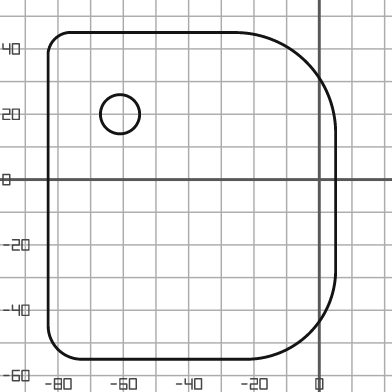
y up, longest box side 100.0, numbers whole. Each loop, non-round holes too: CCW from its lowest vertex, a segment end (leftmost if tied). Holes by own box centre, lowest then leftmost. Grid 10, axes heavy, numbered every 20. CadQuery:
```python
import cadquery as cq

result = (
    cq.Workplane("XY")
    .moveTo(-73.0, -55.0)
    .lineTo(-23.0, -55.0)
    .threePointArc((-3.0, -47.0), (5.0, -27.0))
    .lineTo(5.0, 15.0)
    .threePointArc((-4.0, 36.0), (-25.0, 45.0))
    .lineTo(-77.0, 45.0)
    .threePointArc((-81.0, 43.0), (-83.0, 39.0))
    .lineTo(-83.0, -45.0)
    .threePointArc((-80.0, -52.0), (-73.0, -55.0))
    .close()
    .moveTo(-61.0, 20.0)
    .circle(6.0)
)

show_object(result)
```